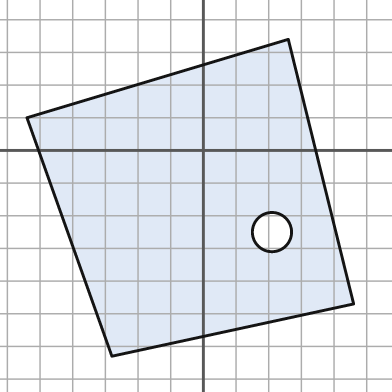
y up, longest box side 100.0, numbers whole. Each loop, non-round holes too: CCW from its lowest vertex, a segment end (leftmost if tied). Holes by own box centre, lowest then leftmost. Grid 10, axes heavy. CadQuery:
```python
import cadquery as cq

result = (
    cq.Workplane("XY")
    .moveTo(-28.0, -63.0)
    .lineTo(46.0, -47.0)
    .lineTo(26.0, 34.0)
    .lineTo(-54.0, 10.0)
    .close()
    .moveTo(21.0, -25.0)
    .circle(6.0)
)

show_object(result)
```